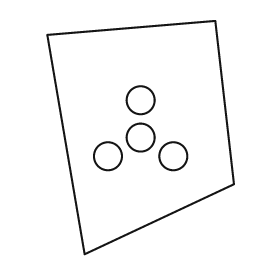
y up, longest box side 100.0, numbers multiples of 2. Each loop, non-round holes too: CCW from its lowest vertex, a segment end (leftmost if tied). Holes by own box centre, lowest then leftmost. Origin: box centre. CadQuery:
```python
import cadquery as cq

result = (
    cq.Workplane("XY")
    .moveTo(-24.0, -50.0)
    .lineTo(40.0, -20.0)
    .lineTo(32.0, 50.0)
    .lineTo(-40.0, 44.0)
    .close()
    .moveTo(-14.0, -8.0)
    .circle(6.0)
    .moveTo(14.0, -8.0)
    .circle(6.0)
    .moveTo(0.0, 0.0)
    .circle(6.0)
    .moveTo(0.0, 16.0)
    .circle(6.0)
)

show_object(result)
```